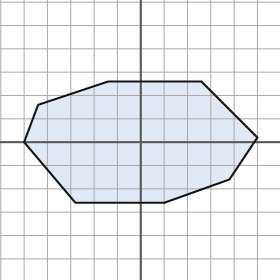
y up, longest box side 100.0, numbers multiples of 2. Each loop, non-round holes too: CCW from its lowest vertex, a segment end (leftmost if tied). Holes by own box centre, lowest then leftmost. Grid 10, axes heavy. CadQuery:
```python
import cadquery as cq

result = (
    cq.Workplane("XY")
    .moveTo(-28.0, -26.0)
    .lineTo(10.0, -26.0)
    .lineTo(38.0, -16.0)
    .lineTo(50.0, 2.0)
    .lineTo(26.0, 26.0)
    .lineTo(-14.0, 26.0)
    .lineTo(-44.0, 16.0)
    .lineTo(-50.0, 0.0)
    .close()
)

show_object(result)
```